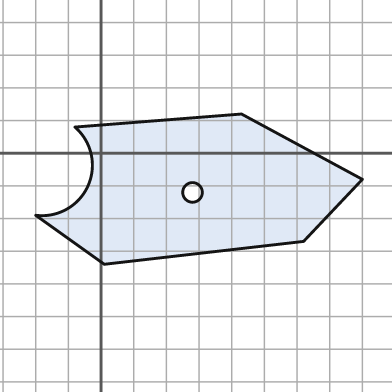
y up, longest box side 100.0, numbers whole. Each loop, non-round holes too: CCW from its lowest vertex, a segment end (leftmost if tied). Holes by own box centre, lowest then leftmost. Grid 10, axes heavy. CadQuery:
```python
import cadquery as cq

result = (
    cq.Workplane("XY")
    .moveTo(1.0, -34.0)
    .lineTo(62.0, -27.0)
    .lineTo(80.0, -8.0)
    .lineTo(43.0, 12.0)
    .lineTo(-8.0, 8.0)
    .threePointArc((-4.0, -10.0), (-20.0, -19.0))
    .close()
    .moveTo(28.0, -12.0)
    .circle(3.0)
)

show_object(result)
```